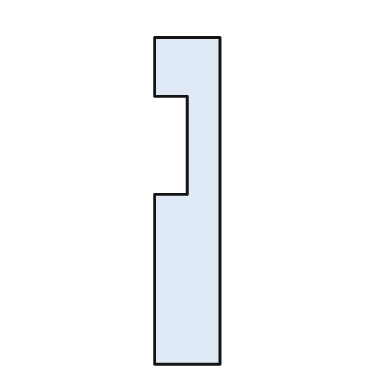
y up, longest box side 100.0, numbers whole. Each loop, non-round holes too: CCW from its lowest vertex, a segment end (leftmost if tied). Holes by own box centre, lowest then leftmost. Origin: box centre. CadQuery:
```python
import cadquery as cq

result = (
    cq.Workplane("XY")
    .moveTo(-10.0, -50.0)
    .lineTo(10.0, -50.0)
    .lineTo(10.0, 50.0)
    .lineTo(-10.0, 50.0)
    .lineTo(-10.0, 32.0)
    .lineTo(0.0, 32.0)
    .lineTo(0.0, 2.0)
    .lineTo(-10.0, 2.0)
    .close()
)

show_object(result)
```